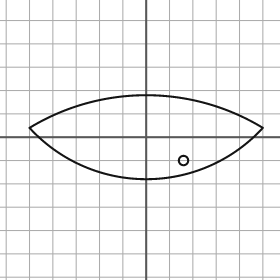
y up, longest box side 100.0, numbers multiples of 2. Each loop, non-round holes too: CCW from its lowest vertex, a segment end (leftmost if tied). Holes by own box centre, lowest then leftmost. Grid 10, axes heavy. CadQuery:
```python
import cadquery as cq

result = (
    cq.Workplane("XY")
    .moveTo(-50.0, 4.0)
    .threePointArc((0.0, -18.0), (50.0, 4.0))
    .threePointArc((0.0, 18.0), (-50.0, 4.0))
    .close()
    .moveTo(16.0, -10.0)
    .circle(2.0)
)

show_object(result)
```